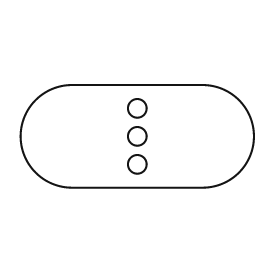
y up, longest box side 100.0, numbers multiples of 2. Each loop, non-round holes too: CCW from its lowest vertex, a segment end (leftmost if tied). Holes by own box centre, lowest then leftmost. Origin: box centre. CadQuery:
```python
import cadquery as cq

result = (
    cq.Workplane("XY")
    .moveTo(-28.0, -22.0)
    .lineTo(28.0, -22.0)
    .threePointArc((50.0, 0.0), (28.0, 22.0))
    .lineTo(-28.0, 22.0)
    .threePointArc((-50.0, 0.0), (-28.0, -22.0))
    .close()
    .moveTo(0.0, -12.0)
    .circle(4.0)
    .moveTo(0.0, 0.0)
    .circle(4.0)
    .moveTo(0.0, 12.0)
    .circle(4.0)
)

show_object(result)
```